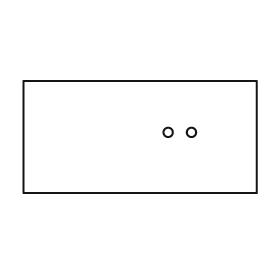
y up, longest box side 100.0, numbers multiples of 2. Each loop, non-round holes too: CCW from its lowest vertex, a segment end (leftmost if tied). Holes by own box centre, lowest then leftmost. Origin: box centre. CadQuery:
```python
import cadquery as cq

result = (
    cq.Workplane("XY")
    .moveTo(-50.0, -24.0)
    .lineTo(50.0, -24.0)
    .lineTo(50.0, 24.0)
    .lineTo(-50.0, 24.0)
    .close()
    .moveTo(12.0, 2.0)
    .circle(2.0)
    .moveTo(22.0, 2.0)
    .circle(2.0)
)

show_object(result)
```